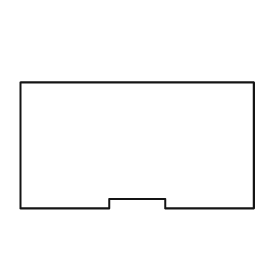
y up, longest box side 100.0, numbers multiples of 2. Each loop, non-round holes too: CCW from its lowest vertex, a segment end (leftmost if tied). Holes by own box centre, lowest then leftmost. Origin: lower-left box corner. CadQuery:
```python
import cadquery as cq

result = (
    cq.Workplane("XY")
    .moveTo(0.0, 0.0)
    .lineTo(38.0, 0.0)
    .lineTo(38.0, 4.0)
    .lineTo(62.0, 4.0)
    .lineTo(62.0, 0.0)
    .lineTo(100.0, 0.0)
    .lineTo(100.0, 54.0)
    .lineTo(0.0, 54.0)
    .close()
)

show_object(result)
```